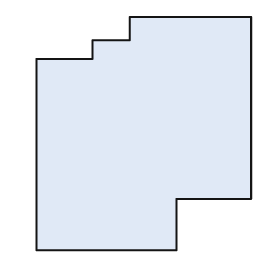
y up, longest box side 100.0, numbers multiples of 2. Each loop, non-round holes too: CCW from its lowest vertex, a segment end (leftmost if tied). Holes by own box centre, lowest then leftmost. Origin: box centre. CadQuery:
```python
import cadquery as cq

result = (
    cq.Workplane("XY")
    .moveTo(-46.0, -50.0)
    .lineTo(14.0, -50.0)
    .lineTo(14.0, -28.0)
    .lineTo(46.0, -28.0)
    .lineTo(46.0, 50.0)
    .lineTo(-6.0, 50.0)
    .lineTo(-6.0, 40.0)
    .lineTo(-22.0, 40.0)
    .lineTo(-22.0, 32.0)
    .lineTo(-46.0, 32.0)
    .close()
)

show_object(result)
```